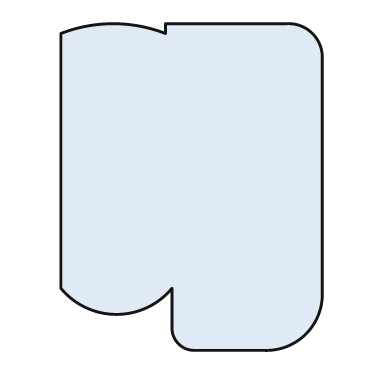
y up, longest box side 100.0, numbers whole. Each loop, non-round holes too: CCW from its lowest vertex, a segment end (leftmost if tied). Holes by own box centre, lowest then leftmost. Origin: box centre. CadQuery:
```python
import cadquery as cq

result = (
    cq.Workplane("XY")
    .moveTo(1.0, -50.0)
    .lineTo(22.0, -50.0)
    .threePointArc((35.0, -45.0), (40.0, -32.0))
    .lineTo(40.0, 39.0)
    .threePointArc((37.0, 47.0), (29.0, 50.0))
    .lineTo(-8.0, 50.0)
    .lineTo(-8.0, 47.0)
    .threePointArc((-24.0, 50.0), (-40.0, 47.0))
    .lineTo(-40.0, -31.0)
    .threePointArc((-23.0, -39.0), (-6.0, -31.0))
    .lineTo(-6.0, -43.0)
    .threePointArc((-4.0, -48.0), (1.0, -50.0))
    .close()
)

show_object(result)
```